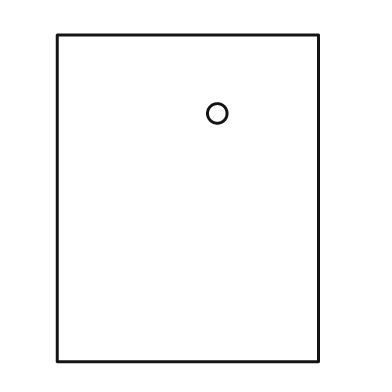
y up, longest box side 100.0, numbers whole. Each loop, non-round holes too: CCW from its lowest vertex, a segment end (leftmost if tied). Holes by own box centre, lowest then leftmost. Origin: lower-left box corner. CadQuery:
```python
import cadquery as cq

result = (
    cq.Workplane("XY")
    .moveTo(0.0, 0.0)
    .lineTo(80.0, 0.0)
    .lineTo(80.0, 100.0)
    .lineTo(0.0, 100.0)
    .close()
    .moveTo(49.0, 76.0)
    .circle(3.0)
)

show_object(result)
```